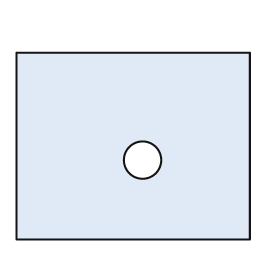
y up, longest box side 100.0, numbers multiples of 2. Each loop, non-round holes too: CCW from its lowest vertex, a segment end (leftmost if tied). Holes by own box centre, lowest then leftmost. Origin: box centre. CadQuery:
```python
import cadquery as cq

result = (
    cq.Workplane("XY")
    .moveTo(-50.0, -40.0)
    .lineTo(50.0, -40.0)
    .lineTo(50.0, 40.0)
    .lineTo(-50.0, 40.0)
    .close()
    .moveTo(4.0, -6.0)
    .circle(8.0)
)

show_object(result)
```